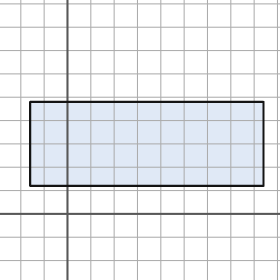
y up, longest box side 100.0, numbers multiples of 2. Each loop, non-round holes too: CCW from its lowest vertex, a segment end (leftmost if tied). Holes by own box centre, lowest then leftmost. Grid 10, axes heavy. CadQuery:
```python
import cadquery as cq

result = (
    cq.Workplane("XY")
    .moveTo(-16.0, 12.0)
    .lineTo(84.0, 12.0)
    .lineTo(84.0, 48.0)
    .lineTo(-16.0, 48.0)
    .close()
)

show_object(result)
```